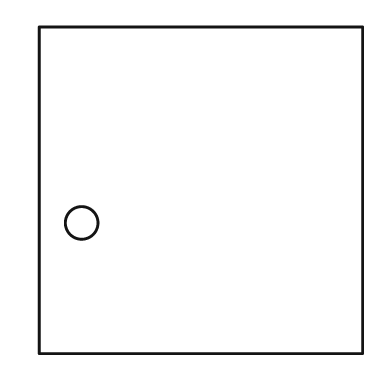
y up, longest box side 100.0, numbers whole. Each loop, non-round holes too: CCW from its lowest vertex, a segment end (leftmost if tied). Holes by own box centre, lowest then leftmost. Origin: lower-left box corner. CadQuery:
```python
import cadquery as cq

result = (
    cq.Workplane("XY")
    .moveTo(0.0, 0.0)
    .lineTo(99.0, 0.0)
    .lineTo(99.0, 100.0)
    .lineTo(0.0, 100.0)
    .close()
    .moveTo(13.0, 40.0)
    .circle(5.0)
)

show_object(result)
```